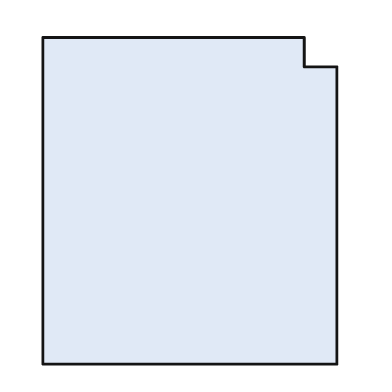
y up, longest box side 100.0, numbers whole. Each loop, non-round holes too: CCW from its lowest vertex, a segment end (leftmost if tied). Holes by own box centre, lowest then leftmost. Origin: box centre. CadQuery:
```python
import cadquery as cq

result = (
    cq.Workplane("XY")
    .moveTo(-45.0, -50.0)
    .lineTo(45.0, -50.0)
    .lineTo(45.0, 41.0)
    .lineTo(35.0, 41.0)
    .lineTo(35.0, 50.0)
    .lineTo(-45.0, 50.0)
    .close()
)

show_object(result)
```